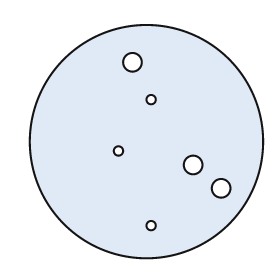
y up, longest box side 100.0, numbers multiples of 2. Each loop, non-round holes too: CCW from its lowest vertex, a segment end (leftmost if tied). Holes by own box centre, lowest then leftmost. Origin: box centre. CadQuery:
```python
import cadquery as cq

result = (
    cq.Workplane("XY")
    .moveTo(0.0, 0.0)
    .circle(50.0)
    .moveTo(2.0, -36.0)
    .circle(2.0)
    .moveTo(32.0, -20.0)
    .circle(4.0)
    .moveTo(20.0, -10.0)
    .circle(4.0)
    .moveTo(-12.0, -4.0)
    .circle(2.0)
    .moveTo(2.0, 18.0)
    .circle(2.0)
    .moveTo(-6.0, 34.0)
    .circle(4.0)
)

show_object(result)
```